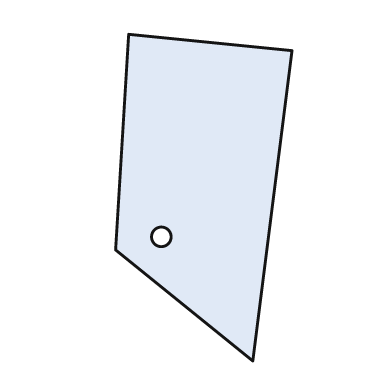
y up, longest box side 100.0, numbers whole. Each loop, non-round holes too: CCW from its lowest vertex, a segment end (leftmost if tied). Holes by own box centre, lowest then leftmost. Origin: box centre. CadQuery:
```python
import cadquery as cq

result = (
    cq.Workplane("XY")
    .moveTo(15.0, -50.0)
    .lineTo(27.0, 45.0)
    .lineTo(-23.0, 50.0)
    .lineTo(-27.0, -16.0)
    .close()
    .moveTo(-13.0, -12.0)
    .circle(3.0)
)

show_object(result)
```